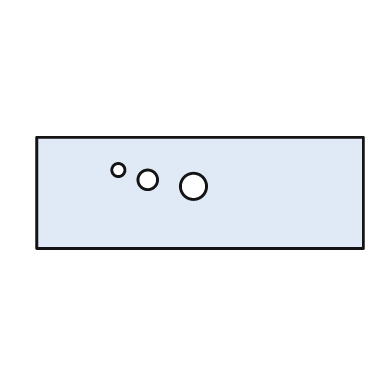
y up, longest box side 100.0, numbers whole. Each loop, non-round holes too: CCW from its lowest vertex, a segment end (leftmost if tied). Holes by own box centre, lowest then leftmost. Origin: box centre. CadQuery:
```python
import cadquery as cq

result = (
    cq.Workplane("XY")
    .moveTo(-50.0, -17.0)
    .lineTo(50.0, -17.0)
    .lineTo(50.0, 17.0)
    .lineTo(-50.0, 17.0)
    .close()
    .moveTo(-2.0, 2.0)
    .circle(4.0)
    .moveTo(-16.0, 4.0)
    .circle(3.0)
    .moveTo(-25.0, 7.0)
    .circle(2.0)
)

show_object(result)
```